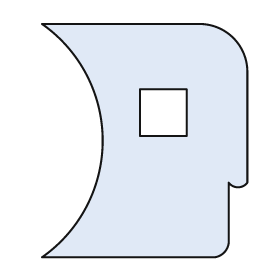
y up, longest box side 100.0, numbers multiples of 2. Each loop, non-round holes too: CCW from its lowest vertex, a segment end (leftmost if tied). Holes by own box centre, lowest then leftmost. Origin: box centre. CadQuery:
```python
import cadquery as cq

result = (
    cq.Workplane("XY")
    .moveTo(-44.0, -50.0)
    .lineTo(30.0, -50.0)
    .threePointArc((34.0, -48.0), (36.0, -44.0))
    .lineTo(36.0, -18.0)
    .threePointArc((40.0, -20.0), (44.0, -18.0))
    .lineTo(44.0, 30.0)
    .threePointArc((38.0, 44.0), (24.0, 50.0))
    .lineTo(-44.0, 50.0)
    .threePointArc((-18.0, 0.0), (-44.0, -50.0))
    .close()
    .moveTo(-2.0, 2.0)
    .lineTo(18.0, 2.0)
    .lineTo(18.0, 22.0)
    .lineTo(-2.0, 22.0)
    .close()
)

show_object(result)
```